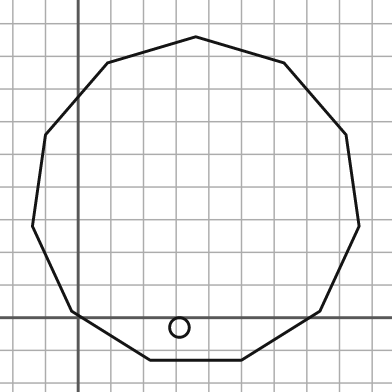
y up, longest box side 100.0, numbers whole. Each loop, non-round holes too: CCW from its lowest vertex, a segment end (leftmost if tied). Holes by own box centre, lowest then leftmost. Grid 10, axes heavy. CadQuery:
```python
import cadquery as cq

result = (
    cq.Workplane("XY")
    .moveTo(22.0, -13.0)
    .lineTo(50.0, -13.0)
    .lineTo(74.0, 2.0)
    .lineTo(86.0, 28.0)
    .lineTo(82.0, 56.0)
    .lineTo(63.0, 78.0)
    .lineTo(36.0, 86.0)
    .lineTo(9.0, 78.0)
    .lineTo(-10.0, 56.0)
    .lineTo(-14.0, 28.0)
    .lineTo(-2.0, 2.0)
    .close()
    .moveTo(31.0, -3.0)
    .circle(3.0)
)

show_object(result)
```